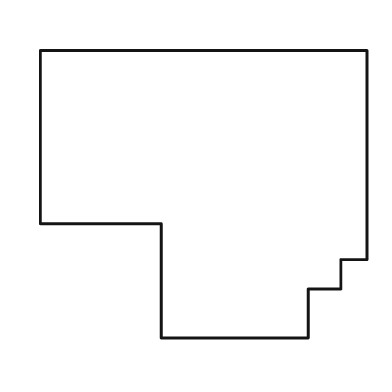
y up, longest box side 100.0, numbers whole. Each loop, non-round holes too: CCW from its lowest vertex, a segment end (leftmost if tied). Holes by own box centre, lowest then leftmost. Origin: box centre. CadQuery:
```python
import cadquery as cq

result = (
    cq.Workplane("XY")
    .moveTo(-13.0, -44.0)
    .lineTo(32.0, -44.0)
    .lineTo(32.0, -29.0)
    .lineTo(42.0, -29.0)
    .lineTo(42.0, -20.0)
    .lineTo(50.0, -20.0)
    .lineTo(50.0, 44.0)
    .lineTo(-50.0, 44.0)
    .lineTo(-50.0, -9.0)
    .lineTo(-13.0, -9.0)
    .close()
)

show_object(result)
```